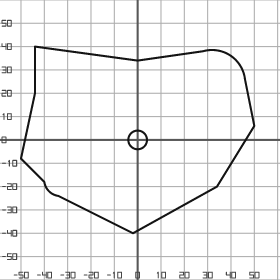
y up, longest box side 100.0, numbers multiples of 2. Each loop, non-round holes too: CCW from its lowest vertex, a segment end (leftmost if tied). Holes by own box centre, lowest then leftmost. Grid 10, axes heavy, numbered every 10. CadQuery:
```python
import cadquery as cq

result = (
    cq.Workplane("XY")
    .moveTo(-2.0, -40.0)
    .lineTo(34.0, -20.0)
    .lineTo(50.0, 6.0)
    .lineTo(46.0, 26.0)
    .threePointArc((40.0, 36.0), (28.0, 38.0))
    .lineTo(0.0, 34.0)
    .lineTo(-44.0, 40.0)
    .lineTo(-44.0, 20.0)
    .lineTo(-50.0, -8.0)
    .lineTo(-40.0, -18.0)
    .threePointArc((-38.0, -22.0), (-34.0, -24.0))
    .close()
    .moveTo(0.0, 0.0)
    .circle(4.0)
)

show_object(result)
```